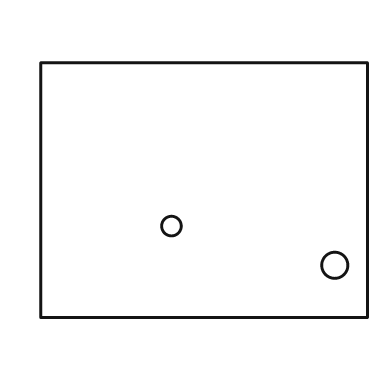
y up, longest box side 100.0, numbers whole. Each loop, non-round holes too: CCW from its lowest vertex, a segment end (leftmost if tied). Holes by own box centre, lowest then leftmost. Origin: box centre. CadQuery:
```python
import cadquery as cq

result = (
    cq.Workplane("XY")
    .moveTo(-50.0, -39.0)
    .lineTo(50.0, -39.0)
    .lineTo(50.0, 39.0)
    .lineTo(-50.0, 39.0)
    .close()
    .moveTo(40.0, -23.0)
    .circle(4.0)
    .moveTo(-10.0, -11.0)
    .circle(3.0)
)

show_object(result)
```